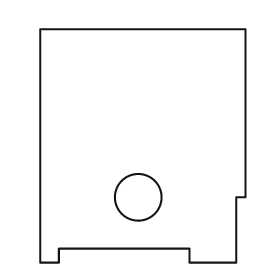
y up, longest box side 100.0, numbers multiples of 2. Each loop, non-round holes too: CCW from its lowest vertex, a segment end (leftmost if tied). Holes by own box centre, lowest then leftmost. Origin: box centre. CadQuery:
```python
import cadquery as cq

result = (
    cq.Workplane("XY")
    .moveTo(-44.0, -50.0)
    .lineTo(-36.0, -50.0)
    .lineTo(-36.0, -44.0)
    .lineTo(20.0, -44.0)
    .lineTo(20.0, -50.0)
    .lineTo(40.0, -50.0)
    .lineTo(40.0, -22.0)
    .lineTo(44.0, -22.0)
    .lineTo(44.0, 50.0)
    .lineTo(-44.0, 50.0)
    .close()
    .moveTo(-2.0, -22.0)
    .circle(10.0)
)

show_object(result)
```